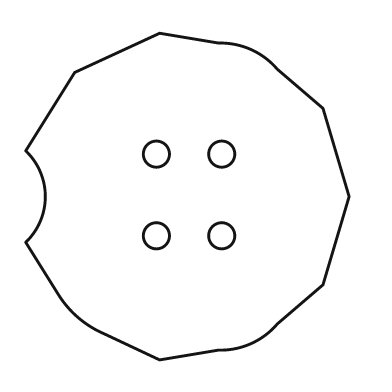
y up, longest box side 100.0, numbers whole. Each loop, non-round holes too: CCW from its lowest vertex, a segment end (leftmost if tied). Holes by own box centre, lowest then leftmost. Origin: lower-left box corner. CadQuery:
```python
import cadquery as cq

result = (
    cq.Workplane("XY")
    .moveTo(41.0, 0.0)
    .lineTo(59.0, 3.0)
    .threePointArc((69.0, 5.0), (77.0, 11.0))
    .lineTo(91.0, 23.0)
    .lineTo(99.0, 50.0)
    .lineTo(91.0, 77.0)
    .lineTo(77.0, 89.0)
    .threePointArc((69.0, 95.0), (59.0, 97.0))
    .lineTo(41.0, 100.0)
    .lineTo(15.0, 88.0)
    .lineTo(0.0, 64.0)
    .threePointArc((6.0, 50.0), (0.0, 36.0))
    .lineTo(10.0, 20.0)
    .threePointArc((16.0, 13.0), (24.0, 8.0))
    .close()
    .moveTo(40.0, 38.0)
    .circle(4.0)
    .moveTo(60.0, 38.0)
    .circle(4.0)
    .moveTo(40.0, 63.0)
    .circle(4.0)
    .moveTo(60.0, 63.0)
    .circle(4.0)
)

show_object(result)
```